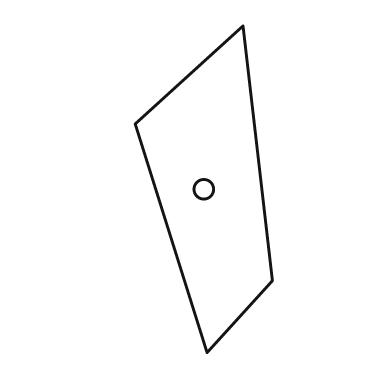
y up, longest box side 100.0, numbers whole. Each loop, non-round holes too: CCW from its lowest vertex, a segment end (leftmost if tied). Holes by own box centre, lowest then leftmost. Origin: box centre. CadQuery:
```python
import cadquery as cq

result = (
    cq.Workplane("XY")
    .moveTo(1.0, -50.0)
    .lineTo(21.0, -28.0)
    .lineTo(12.0, 50.0)
    .lineTo(-21.0, 20.0)
    .close()
    .moveTo(0.0, 0.0)
    .circle(3.0)
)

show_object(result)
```